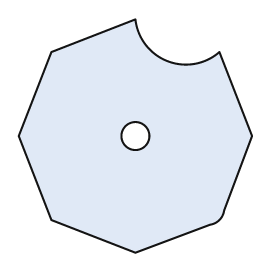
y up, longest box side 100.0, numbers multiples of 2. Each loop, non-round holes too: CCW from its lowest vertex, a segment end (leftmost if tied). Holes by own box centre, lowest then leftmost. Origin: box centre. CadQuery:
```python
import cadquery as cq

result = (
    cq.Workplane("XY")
    .moveTo(0.0, -50.0)
    .lineTo(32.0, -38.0)
    .threePointArc((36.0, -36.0), (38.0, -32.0))
    .lineTo(50.0, 0.0)
    .lineTo(36.0, 36.0)
    .threePointArc((14.0, 32.0), (0.0, 50.0))
    .lineTo(-36.0, 36.0)
    .lineTo(-50.0, 0.0)
    .lineTo(-36.0, -36.0)
    .close()
    .moveTo(0.0, 0.0)
    .circle(6.0)
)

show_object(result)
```